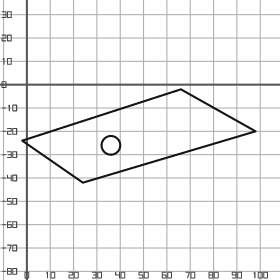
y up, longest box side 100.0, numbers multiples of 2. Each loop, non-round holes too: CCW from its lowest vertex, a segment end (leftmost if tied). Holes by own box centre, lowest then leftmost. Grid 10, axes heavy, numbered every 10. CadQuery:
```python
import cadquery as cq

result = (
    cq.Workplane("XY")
    .moveTo(24.0, -42.0)
    .lineTo(98.0, -20.0)
    .lineTo(66.0, -2.0)
    .lineTo(-2.0, -24.0)
    .close()
    .moveTo(36.0, -26.0)
    .circle(4.0)
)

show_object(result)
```